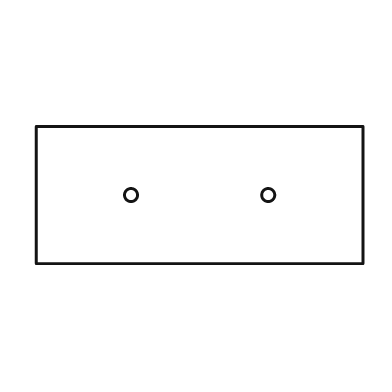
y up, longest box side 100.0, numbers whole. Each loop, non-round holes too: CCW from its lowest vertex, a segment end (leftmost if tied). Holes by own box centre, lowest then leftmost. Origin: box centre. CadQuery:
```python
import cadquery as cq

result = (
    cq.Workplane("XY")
    .moveTo(-50.0, -21.0)
    .lineTo(50.0, -21.0)
    .lineTo(50.0, 21.0)
    .lineTo(-50.0, 21.0)
    .close()
    .moveTo(-21.0, 0.0)
    .circle(2.0)
    .moveTo(21.0, 0.0)
    .circle(2.0)
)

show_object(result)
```